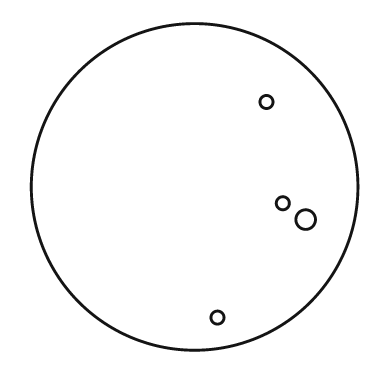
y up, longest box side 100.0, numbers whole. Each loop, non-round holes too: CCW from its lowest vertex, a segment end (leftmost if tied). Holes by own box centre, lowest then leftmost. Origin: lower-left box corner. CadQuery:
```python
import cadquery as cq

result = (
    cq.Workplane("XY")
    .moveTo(50.0, 50.0)
    .circle(50.0)
    .moveTo(57.0, 10.0)
    .circle(2.0)
    .moveTo(84.0, 40.0)
    .circle(3.0)
    .moveTo(77.0, 45.0)
    .circle(2.0)
    .moveTo(72.0, 76.0)
    .circle(2.0)
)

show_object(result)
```